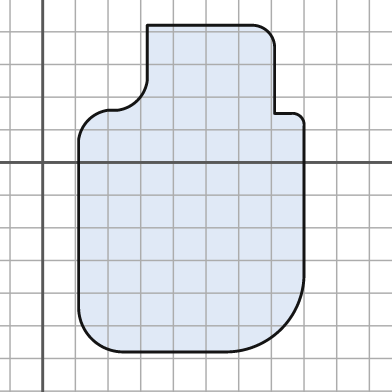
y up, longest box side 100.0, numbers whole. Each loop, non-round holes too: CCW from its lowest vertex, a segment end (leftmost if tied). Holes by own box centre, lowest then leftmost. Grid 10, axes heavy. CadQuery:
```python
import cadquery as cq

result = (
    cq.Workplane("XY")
    .moveTo(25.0, -58.0)
    .lineTo(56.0, -58.0)
    .threePointArc((73.0, -51.0), (80.0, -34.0))
    .lineTo(80.0, 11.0)
    .threePointArc((79.0, 14.0), (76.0, 15.0))
    .lineTo(71.0, 15.0)
    .lineTo(71.0, 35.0)
    .threePointArc((69.0, 40.0), (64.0, 42.0))
    .lineTo(32.0, 42.0)
    .lineTo(32.0, 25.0)
    .threePointArc((29.0, 19.0), (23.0, 16.0))
    .lineTo(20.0, 16.0)
    .threePointArc((14.0, 13.0), (11.0, 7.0))
    .lineTo(11.0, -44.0)
    .threePointArc((15.0, -54.0), (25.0, -58.0))
    .close()
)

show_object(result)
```